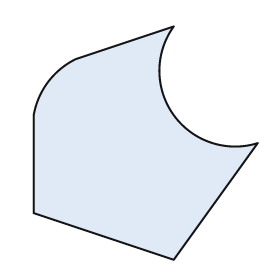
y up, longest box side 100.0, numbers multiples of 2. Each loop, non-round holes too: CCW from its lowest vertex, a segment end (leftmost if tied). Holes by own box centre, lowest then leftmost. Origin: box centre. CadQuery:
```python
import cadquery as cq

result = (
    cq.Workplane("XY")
    .moveTo(12.0, -50.0)
    .lineTo(48.0, 0.0)
    .threePointArc((12.0, 12.0), (12.0, 50.0))
    .lineTo(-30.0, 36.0)
    .threePointArc((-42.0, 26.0), (-48.0, 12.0))
    .lineTo(-48.0, -30.0)
    .close()
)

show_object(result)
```